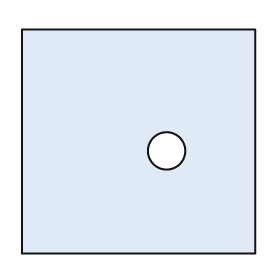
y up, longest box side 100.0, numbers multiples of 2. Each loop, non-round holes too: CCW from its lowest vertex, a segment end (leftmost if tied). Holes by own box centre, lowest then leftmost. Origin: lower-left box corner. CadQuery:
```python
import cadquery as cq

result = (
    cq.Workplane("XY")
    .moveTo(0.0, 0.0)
    .lineTo(100.0, 0.0)
    .lineTo(100.0, 96.0)
    .lineTo(0.0, 96.0)
    .close()
    .moveTo(62.0, 44.0)
    .circle(8.0)
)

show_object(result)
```